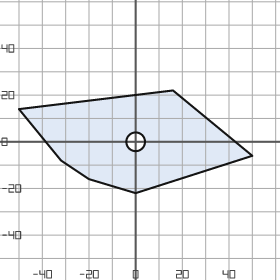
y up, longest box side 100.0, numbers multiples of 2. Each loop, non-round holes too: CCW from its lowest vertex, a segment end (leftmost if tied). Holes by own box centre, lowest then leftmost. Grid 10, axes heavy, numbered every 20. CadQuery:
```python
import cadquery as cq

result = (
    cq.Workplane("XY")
    .moveTo(0.0, -22.0)
    .lineTo(50.0, -6.0)
    .lineTo(16.0, 22.0)
    .lineTo(-50.0, 14.0)
    .lineTo(-32.0, -8.0)
    .lineTo(-20.0, -16.0)
    .close()
    .moveTo(0.0, 0.0)
    .circle(4.0)
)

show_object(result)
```